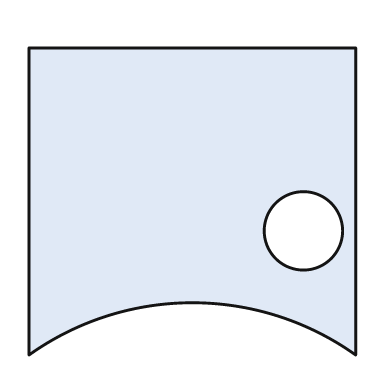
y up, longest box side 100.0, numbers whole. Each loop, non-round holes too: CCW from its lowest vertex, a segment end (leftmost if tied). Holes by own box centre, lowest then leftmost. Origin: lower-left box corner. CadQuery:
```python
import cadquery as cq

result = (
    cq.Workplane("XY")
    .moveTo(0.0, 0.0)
    .threePointArc((50.0, 16.0), (100.0, 0.0))
    .lineTo(100.0, 94.0)
    .lineTo(0.0, 94.0)
    .close()
    .moveTo(84.0, 38.0)
    .circle(12.0)
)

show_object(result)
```